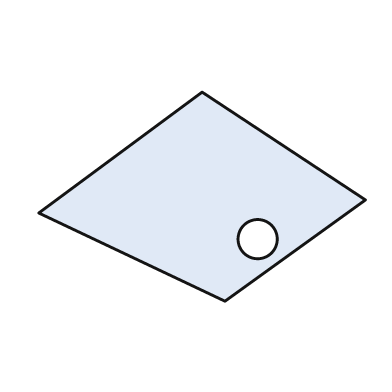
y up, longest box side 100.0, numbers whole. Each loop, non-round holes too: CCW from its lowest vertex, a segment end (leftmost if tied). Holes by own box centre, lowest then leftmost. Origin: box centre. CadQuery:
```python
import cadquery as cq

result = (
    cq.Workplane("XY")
    .moveTo(7.0, -32.0)
    .lineTo(50.0, -1.0)
    .lineTo(0.0, 32.0)
    .lineTo(-50.0, -5.0)
    .close()
    .moveTo(17.0, -13.0)
    .circle(6.0)
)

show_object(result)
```